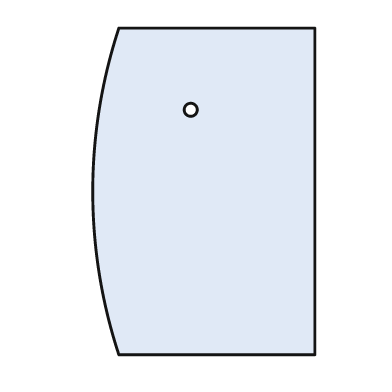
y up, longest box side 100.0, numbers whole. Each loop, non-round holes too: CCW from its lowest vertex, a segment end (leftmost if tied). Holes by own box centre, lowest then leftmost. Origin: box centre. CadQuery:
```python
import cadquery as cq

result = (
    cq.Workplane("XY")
    .moveTo(-26.0, -50.0)
    .lineTo(34.0, -50.0)
    .lineTo(34.0, 50.0)
    .lineTo(-26.0, 50.0)
    .threePointArc((-34.0, 0.0), (-26.0, -50.0))
    .close()
    .moveTo(-4.0, 25.0)
    .circle(2.0)
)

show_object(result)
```